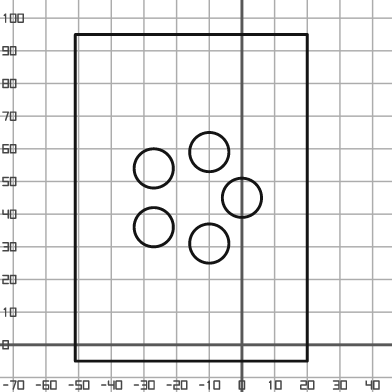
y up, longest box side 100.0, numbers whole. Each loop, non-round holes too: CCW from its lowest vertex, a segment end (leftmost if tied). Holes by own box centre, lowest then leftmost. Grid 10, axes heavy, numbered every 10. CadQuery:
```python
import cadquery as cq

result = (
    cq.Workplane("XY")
    .moveTo(-51.0, -5.0)
    .lineTo(20.0, -5.0)
    .lineTo(20.0, 95.0)
    .lineTo(-51.0, 95.0)
    .close()
    .moveTo(-10.0, 31.0)
    .circle(6.0)
    .moveTo(-27.0, 36.0)
    .circle(6.0)
    .moveTo(0.0, 45.0)
    .circle(6.0)
    .moveTo(-27.0, 54.0)
    .circle(6.0)
    .moveTo(-10.0, 59.0)
    .circle(6.0)
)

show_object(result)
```